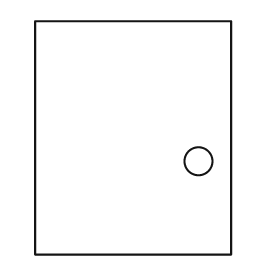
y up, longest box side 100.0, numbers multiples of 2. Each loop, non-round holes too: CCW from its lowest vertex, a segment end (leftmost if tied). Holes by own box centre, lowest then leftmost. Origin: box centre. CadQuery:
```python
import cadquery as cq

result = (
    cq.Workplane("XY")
    .moveTo(-42.0, -50.0)
    .lineTo(42.0, -50.0)
    .lineTo(42.0, 50.0)
    .lineTo(-42.0, 50.0)
    .close()
    .moveTo(28.0, -10.0)
    .circle(6.0)
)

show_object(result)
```